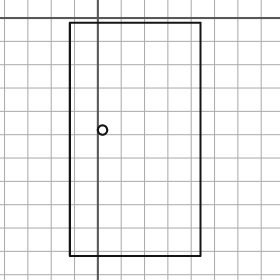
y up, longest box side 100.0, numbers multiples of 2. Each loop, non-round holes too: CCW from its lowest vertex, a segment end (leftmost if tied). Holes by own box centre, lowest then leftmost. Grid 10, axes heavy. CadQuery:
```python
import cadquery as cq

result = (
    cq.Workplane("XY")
    .moveTo(-12.0, -102.0)
    .lineTo(44.0, -102.0)
    .lineTo(44.0, -2.0)
    .lineTo(-12.0, -2.0)
    .close()
    .moveTo(2.0, -48.0)
    .circle(2.0)
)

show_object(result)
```